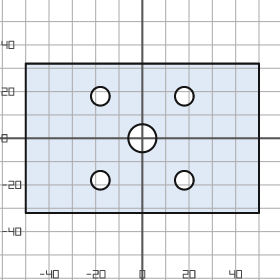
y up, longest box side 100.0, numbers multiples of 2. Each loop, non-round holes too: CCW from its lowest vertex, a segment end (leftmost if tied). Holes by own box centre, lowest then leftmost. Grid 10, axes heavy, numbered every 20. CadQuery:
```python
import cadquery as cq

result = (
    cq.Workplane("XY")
    .moveTo(-50.0, -32.0)
    .lineTo(50.0, -32.0)
    .lineTo(50.0, 32.0)
    .lineTo(-50.0, 32.0)
    .close()
    .moveTo(-18.0, -18.0)
    .circle(4.0)
    .moveTo(18.0, -18.0)
    .circle(4.0)
    .moveTo(0.0, 0.0)
    .circle(6.0)
    .moveTo(-18.0, 18.0)
    .circle(4.0)
    .moveTo(18.0, 18.0)
    .circle(4.0)
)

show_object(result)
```